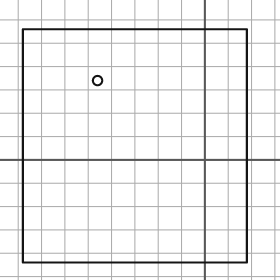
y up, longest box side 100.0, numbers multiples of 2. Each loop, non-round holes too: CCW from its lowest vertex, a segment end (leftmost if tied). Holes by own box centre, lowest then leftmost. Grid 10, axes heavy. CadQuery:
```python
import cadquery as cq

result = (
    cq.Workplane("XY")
    .moveTo(-78.0, -44.0)
    .lineTo(18.0, -44.0)
    .lineTo(18.0, 56.0)
    .lineTo(-78.0, 56.0)
    .close()
    .moveTo(-46.0, 34.0)
    .circle(2.0)
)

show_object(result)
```